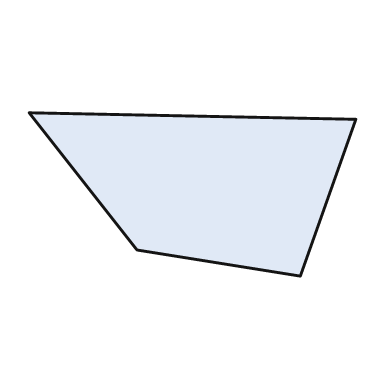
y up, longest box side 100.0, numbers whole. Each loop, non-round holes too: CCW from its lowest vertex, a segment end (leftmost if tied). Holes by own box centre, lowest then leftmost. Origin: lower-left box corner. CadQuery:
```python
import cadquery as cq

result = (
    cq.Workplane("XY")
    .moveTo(83.0, 0.0)
    .lineTo(100.0, 48.0)
    .lineTo(0.0, 50.0)
    .lineTo(33.0, 8.0)
    .close()
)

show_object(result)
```